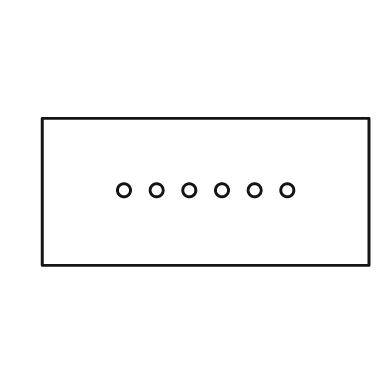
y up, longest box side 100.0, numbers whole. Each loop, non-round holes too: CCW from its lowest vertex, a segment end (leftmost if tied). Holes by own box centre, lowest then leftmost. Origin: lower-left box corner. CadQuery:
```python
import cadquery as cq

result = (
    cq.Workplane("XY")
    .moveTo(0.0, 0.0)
    .lineTo(100.0, 0.0)
    .lineTo(100.0, 45.0)
    .lineTo(0.0, 45.0)
    .close()
    .moveTo(25.0, 23.0)
    .circle(2.0)
    .moveTo(35.0, 23.0)
    .circle(2.0)
    .moveTo(45.0, 23.0)
    .circle(2.0)
    .moveTo(55.0, 23.0)
    .circle(2.0)
    .moveTo(65.0, 23.0)
    .circle(2.0)
    .moveTo(75.0, 23.0)
    .circle(2.0)
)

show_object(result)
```